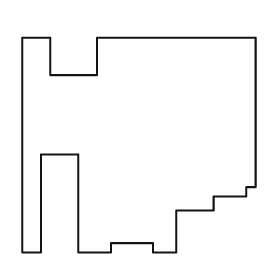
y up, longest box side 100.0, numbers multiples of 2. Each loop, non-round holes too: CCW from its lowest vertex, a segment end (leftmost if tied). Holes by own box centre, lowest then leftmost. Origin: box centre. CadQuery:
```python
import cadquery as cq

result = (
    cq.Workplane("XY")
    .moveTo(-50.0, -46.0)
    .lineTo(-42.0, -46.0)
    .lineTo(-42.0, -4.0)
    .lineTo(-26.0, -4.0)
    .lineTo(-26.0, -46.0)
    .lineTo(-12.0, -46.0)
    .lineTo(-12.0, -42.0)
    .lineTo(6.0, -42.0)
    .lineTo(6.0, -46.0)
    .lineTo(16.0, -46.0)
    .lineTo(16.0, -28.0)
    .lineTo(32.0, -28.0)
    .lineTo(32.0, -22.0)
    .lineTo(46.0, -22.0)
    .lineTo(46.0, -18.0)
    .lineTo(50.0, -18.0)
    .lineTo(50.0, 46.0)
    .lineTo(-18.0, 46.0)
    .lineTo(-18.0, 30.0)
    .lineTo(-38.0, 30.0)
    .lineTo(-38.0, 46.0)
    .lineTo(-50.0, 46.0)
    .close()
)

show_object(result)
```